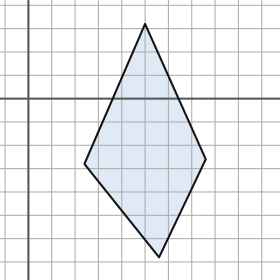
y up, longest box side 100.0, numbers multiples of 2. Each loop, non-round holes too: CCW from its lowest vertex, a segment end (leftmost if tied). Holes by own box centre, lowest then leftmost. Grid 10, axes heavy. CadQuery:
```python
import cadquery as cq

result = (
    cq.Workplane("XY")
    .moveTo(56.0, -68.0)
    .lineTo(76.0, -26.0)
    .lineTo(50.0, 32.0)
    .lineTo(24.0, -28.0)
    .close()
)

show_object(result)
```